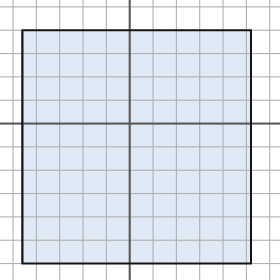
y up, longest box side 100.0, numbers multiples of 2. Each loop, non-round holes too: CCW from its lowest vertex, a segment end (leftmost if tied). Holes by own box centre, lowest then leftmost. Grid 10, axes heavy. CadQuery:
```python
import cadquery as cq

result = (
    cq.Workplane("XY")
    .moveTo(-46.0, -60.0)
    .lineTo(52.0, -60.0)
    .lineTo(52.0, 40.0)
    .lineTo(-46.0, 40.0)
    .close()
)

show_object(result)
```